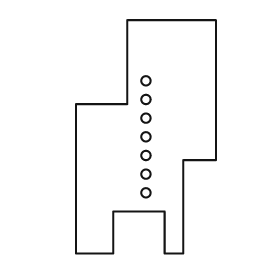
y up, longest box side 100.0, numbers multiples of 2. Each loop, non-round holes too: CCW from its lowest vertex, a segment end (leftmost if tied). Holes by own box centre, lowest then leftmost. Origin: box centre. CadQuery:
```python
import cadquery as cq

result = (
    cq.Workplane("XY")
    .moveTo(-30.0, -50.0)
    .lineTo(-14.0, -50.0)
    .lineTo(-14.0, -32.0)
    .lineTo(8.0, -32.0)
    .lineTo(8.0, -50.0)
    .lineTo(16.0, -50.0)
    .lineTo(16.0, -10.0)
    .lineTo(30.0, -10.0)
    .lineTo(30.0, 50.0)
    .lineTo(-8.0, 50.0)
    .lineTo(-8.0, 14.0)
    .lineTo(-30.0, 14.0)
    .close()
    .moveTo(0.0, -24.0)
    .circle(2.0)
    .moveTo(0.0, -16.0)
    .circle(2.0)
    .moveTo(0.0, -8.0)
    .circle(2.0)
    .moveTo(0.0, 0.0)
    .circle(2.0)
    .moveTo(0.0, 8.0)
    .circle(2.0)
    .moveTo(0.0, 16.0)
    .circle(2.0)
    .moveTo(0.0, 24.0)
    .circle(2.0)
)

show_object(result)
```